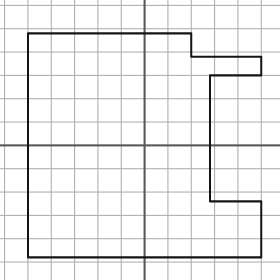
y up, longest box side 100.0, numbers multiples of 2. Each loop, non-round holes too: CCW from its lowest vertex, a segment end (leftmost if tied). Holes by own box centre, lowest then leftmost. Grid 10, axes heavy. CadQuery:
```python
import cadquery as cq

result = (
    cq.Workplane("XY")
    .moveTo(-50.0, -48.0)
    .lineTo(50.0, -48.0)
    .lineTo(50.0, -24.0)
    .lineTo(28.0, -24.0)
    .lineTo(28.0, 30.0)
    .lineTo(50.0, 30.0)
    .lineTo(50.0, 38.0)
    .lineTo(20.0, 38.0)
    .lineTo(20.0, 48.0)
    .lineTo(-50.0, 48.0)
    .close()
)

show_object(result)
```